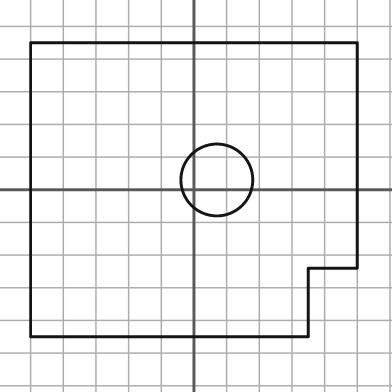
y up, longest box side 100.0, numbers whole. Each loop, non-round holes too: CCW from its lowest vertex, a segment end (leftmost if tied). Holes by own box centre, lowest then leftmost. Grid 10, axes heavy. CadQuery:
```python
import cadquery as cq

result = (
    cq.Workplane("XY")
    .moveTo(-50.0, -45.0)
    .lineTo(35.0, -45.0)
    .lineTo(35.0, -24.0)
    .lineTo(50.0, -24.0)
    .lineTo(50.0, 45.0)
    .lineTo(-50.0, 45.0)
    .close()
    .moveTo(7.0, 3.0)
    .circle(11.0)
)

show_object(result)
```